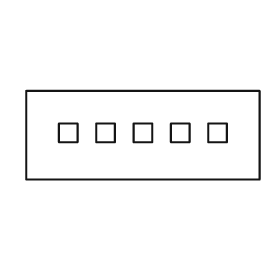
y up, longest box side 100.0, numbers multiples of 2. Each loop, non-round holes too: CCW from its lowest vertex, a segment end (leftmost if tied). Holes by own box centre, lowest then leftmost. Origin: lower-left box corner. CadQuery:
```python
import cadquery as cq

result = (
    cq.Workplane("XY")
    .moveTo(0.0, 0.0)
    .lineTo(100.0, 0.0)
    .lineTo(100.0, 38.0)
    .lineTo(0.0, 38.0)
    .close()
    .moveTo(14.0, 16.0)
    .lineTo(22.0, 16.0)
    .lineTo(22.0, 24.0)
    .lineTo(14.0, 24.0)
    .close()
    .moveTo(30.0, 16.0)
    .lineTo(38.0, 16.0)
    .lineTo(38.0, 24.0)
    .lineTo(30.0, 24.0)
    .close()
    .moveTo(46.0, 16.0)
    .lineTo(54.0, 16.0)
    .lineTo(54.0, 24.0)
    .lineTo(46.0, 24.0)
    .close()
    .moveTo(62.0, 16.0)
    .lineTo(70.0, 16.0)
    .lineTo(70.0, 24.0)
    .lineTo(62.0, 24.0)
    .close()
    .moveTo(78.0, 16.0)
    .lineTo(86.0, 16.0)
    .lineTo(86.0, 24.0)
    .lineTo(78.0, 24.0)
    .close()
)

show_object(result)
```